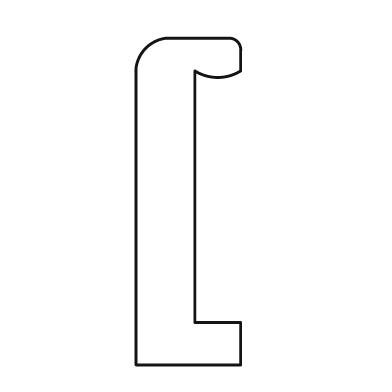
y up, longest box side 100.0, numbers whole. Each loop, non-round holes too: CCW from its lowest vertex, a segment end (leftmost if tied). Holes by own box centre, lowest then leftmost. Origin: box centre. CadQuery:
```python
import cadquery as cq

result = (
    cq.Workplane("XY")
    .moveTo(-16.0, -50.0)
    .lineTo(16.0, -50.0)
    .lineTo(16.0, -37.0)
    .lineTo(2.0, -37.0)
    .lineTo(2.0, 40.0)
    .threePointArc((9.0, 38.0), (16.0, 40.0))
    .lineTo(16.0, 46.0)
    .threePointArc((15.0, 49.0), (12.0, 50.0))
    .lineTo(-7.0, 50.0)
    .threePointArc((-13.0, 47.0), (-16.0, 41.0))
    .close()
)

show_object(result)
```